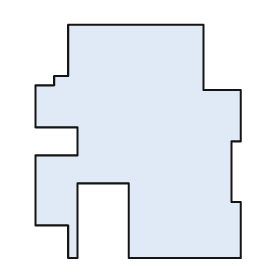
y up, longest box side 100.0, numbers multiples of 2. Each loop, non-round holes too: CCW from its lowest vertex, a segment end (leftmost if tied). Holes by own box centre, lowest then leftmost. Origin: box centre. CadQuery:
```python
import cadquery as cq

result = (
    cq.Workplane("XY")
    .moveTo(-30.0, -50.0)
    .lineTo(-26.0, -50.0)
    .lineTo(-26.0, -18.0)
    .lineTo(-4.0, -18.0)
    .lineTo(-4.0, -50.0)
    .lineTo(44.0, -50.0)
    .lineTo(44.0, -26.0)
    .lineTo(40.0, -26.0)
    .lineTo(40.0, 0.0)
    .lineTo(44.0, 0.0)
    .lineTo(44.0, 22.0)
    .lineTo(28.0, 22.0)
    .lineTo(28.0, 50.0)
    .lineTo(-30.0, 50.0)
    .lineTo(-30.0, 28.0)
    .lineTo(-36.0, 28.0)
    .lineTo(-36.0, 24.0)
    .lineTo(-44.0, 24.0)
    .lineTo(-44.0, 6.0)
    .lineTo(-26.0, 6.0)
    .lineTo(-26.0, -6.0)
    .lineTo(-44.0, -6.0)
    .lineTo(-44.0, -36.0)
    .lineTo(-30.0, -36.0)
    .close()
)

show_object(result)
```